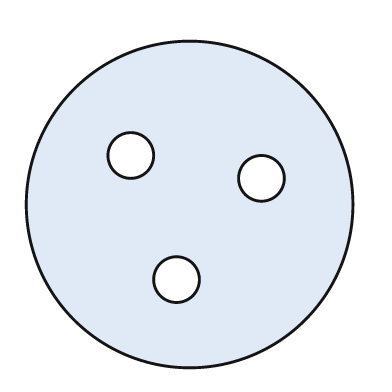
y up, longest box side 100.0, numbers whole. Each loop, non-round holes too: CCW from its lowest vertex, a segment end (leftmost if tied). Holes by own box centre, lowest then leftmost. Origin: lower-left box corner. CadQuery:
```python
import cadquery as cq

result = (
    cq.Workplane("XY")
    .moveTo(50.0, 50.0)
    .circle(50.0)
    .moveTo(46.0, 27.0)
    .circle(7.0)
    .moveTo(72.0, 58.0)
    .circle(7.0)
    .moveTo(32.0, 65.0)
    .circle(7.0)
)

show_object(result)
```